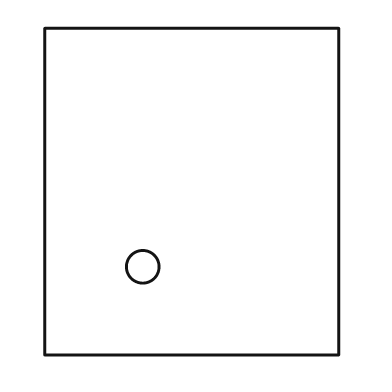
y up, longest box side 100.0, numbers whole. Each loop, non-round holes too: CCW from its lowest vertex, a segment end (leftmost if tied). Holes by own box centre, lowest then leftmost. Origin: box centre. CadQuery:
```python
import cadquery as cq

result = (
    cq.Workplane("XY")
    .moveTo(-45.0, -50.0)
    .lineTo(45.0, -50.0)
    .lineTo(45.0, 50.0)
    .lineTo(-45.0, 50.0)
    .close()
    .moveTo(-15.0, -23.0)
    .circle(5.0)
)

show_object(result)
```